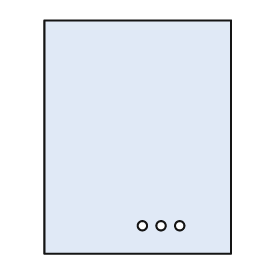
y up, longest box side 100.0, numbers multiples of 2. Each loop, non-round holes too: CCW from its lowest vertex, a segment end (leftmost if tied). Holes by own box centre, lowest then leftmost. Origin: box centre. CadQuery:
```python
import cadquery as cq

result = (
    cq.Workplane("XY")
    .moveTo(-40.0, -50.0)
    .lineTo(40.0, -50.0)
    .lineTo(40.0, 50.0)
    .lineTo(-40.0, 50.0)
    .close()
    .moveTo(2.0, -38.0)
    .circle(2.0)
    .moveTo(10.0, -38.0)
    .circle(2.0)
    .moveTo(18.0, -38.0)
    .circle(2.0)
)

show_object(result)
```